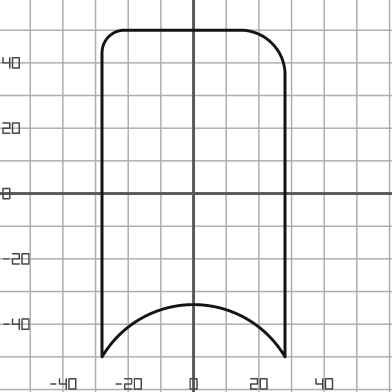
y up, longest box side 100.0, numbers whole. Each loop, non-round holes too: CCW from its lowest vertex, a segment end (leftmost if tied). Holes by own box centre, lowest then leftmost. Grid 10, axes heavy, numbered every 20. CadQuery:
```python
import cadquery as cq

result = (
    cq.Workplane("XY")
    .moveTo(-28.0, -50.0)
    .threePointArc((0.0, -34.0), (28.0, -50.0))
    .lineTo(28.0, 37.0)
    .threePointArc((24.0, 46.0), (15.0, 50.0))
    .lineTo(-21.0, 50.0)
    .threePointArc((-26.0, 48.0), (-28.0, 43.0))
    .close()
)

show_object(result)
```